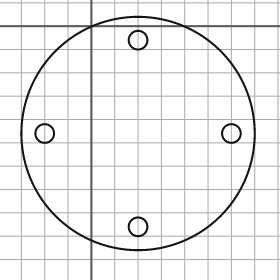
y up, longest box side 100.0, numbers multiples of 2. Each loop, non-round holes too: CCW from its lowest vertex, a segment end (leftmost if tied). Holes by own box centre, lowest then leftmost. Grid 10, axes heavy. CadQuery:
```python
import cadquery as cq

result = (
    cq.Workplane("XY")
    .moveTo(20.0, -46.0)
    .circle(50.0)
    .moveTo(20.0, -86.0)
    .circle(4.0)
    .moveTo(-20.0, -46.0)
    .circle(4.0)
    .moveTo(60.0, -46.0)
    .circle(4.0)
    .moveTo(20.0, -6.0)
    .circle(4.0)
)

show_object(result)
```